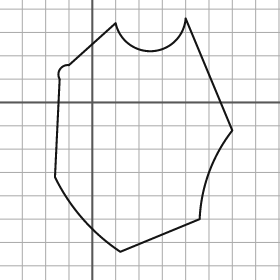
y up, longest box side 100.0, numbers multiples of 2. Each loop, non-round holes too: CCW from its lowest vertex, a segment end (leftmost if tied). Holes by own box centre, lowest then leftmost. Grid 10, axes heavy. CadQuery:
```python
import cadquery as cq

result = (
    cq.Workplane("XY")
    .moveTo(12.0, -64.0)
    .lineTo(46.0, -50.0)
    .threePointArc((50.0, -30.0), (60.0, -12.0))
    .lineTo(40.0, 36.0)
    .threePointArc((26.0, 22.0), (10.0, 34.0))
    .lineTo(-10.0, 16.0)
    .threePointArc((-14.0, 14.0), (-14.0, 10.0))
    .lineTo(-16.0, -32.0)
    .threePointArc((-4.0, -50.0), (12.0, -64.0))
    .close()
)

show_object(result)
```